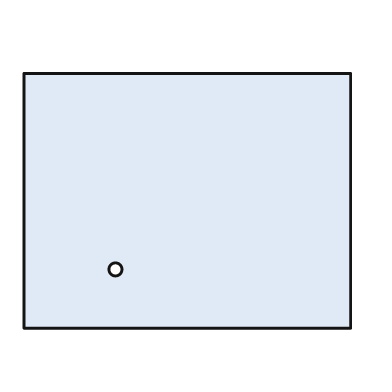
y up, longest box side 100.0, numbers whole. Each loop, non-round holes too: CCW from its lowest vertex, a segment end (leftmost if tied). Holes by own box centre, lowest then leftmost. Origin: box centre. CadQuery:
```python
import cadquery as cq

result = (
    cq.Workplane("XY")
    .moveTo(-50.0, -39.0)
    .lineTo(50.0, -39.0)
    .lineTo(50.0, 39.0)
    .lineTo(-50.0, 39.0)
    .close()
    .moveTo(-22.0, -21.0)
    .circle(2.0)
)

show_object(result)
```